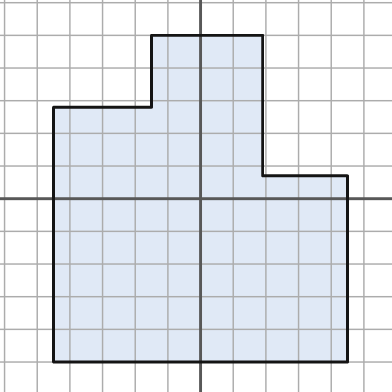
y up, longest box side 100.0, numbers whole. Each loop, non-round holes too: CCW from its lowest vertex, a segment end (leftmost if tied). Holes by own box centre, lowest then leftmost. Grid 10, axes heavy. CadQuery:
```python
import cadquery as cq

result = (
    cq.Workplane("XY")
    .moveTo(-45.0, -50.0)
    .lineTo(45.0, -50.0)
    .lineTo(45.0, 7.0)
    .lineTo(19.0, 7.0)
    .lineTo(19.0, 50.0)
    .lineTo(-15.0, 50.0)
    .lineTo(-15.0, 28.0)
    .lineTo(-45.0, 28.0)
    .close()
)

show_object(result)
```